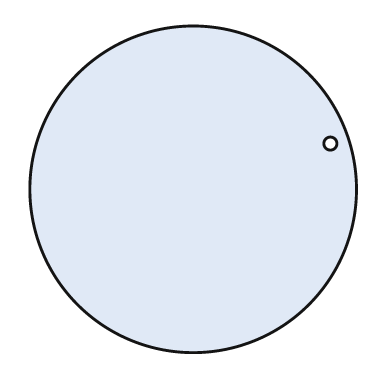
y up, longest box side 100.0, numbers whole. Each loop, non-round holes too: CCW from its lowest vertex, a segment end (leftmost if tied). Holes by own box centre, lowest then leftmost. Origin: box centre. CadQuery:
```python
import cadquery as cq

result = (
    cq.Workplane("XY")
    .moveTo(0.0, 0.0)
    .circle(50.0)
    .moveTo(42.0, 14.0)
    .circle(2.0)
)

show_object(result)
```